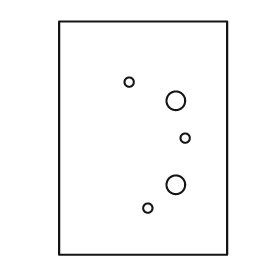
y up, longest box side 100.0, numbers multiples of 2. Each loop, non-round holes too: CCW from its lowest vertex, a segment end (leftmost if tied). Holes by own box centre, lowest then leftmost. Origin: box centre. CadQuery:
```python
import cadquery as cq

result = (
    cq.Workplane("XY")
    .moveTo(-36.0, -50.0)
    .lineTo(36.0, -50.0)
    .lineTo(36.0, 50.0)
    .lineTo(-36.0, 50.0)
    .close()
    .moveTo(2.0, -30.0)
    .circle(2.0)
    .moveTo(14.0, -20.0)
    .circle(4.0)
    .moveTo(18.0, 0.0)
    .circle(2.0)
    .moveTo(14.0, 16.0)
    .circle(4.0)
    .moveTo(-6.0, 24.0)
    .circle(2.0)
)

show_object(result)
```